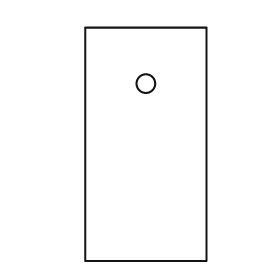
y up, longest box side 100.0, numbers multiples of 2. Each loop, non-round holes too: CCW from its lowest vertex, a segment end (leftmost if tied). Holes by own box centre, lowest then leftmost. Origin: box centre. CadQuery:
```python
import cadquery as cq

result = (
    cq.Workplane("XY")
    .moveTo(-26.0, -50.0)
    .lineTo(26.0, -50.0)
    .lineTo(26.0, 50.0)
    .lineTo(-26.0, 50.0)
    .close()
    .moveTo(0.0, 26.0)
    .circle(4.0)
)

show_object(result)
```